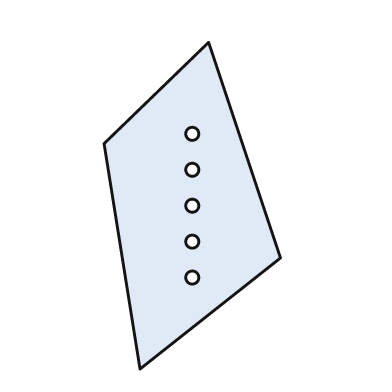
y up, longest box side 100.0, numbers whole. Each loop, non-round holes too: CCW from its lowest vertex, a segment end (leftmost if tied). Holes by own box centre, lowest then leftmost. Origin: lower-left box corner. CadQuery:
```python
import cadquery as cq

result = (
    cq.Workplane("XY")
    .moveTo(11.0, 0.0)
    .lineTo(54.0, 34.0)
    .lineTo(32.0, 100.0)
    .lineTo(0.0, 69.0)
    .close()
    .moveTo(27.0, 28.0)
    .circle(2.0)
    .moveTo(27.0, 39.0)
    .circle(2.0)
    .moveTo(27.0, 50.0)
    .circle(2.0)
    .moveTo(27.0, 61.0)
    .circle(2.0)
    .moveTo(27.0, 72.0)
    .circle(2.0)
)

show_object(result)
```